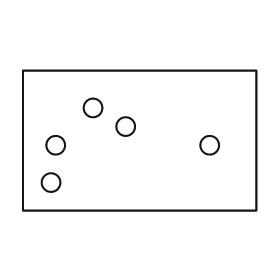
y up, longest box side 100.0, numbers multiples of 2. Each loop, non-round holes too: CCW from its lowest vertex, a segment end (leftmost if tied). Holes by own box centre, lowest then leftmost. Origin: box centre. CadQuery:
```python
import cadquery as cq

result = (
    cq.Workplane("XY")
    .moveTo(-50.0, -30.0)
    .lineTo(50.0, -30.0)
    .lineTo(50.0, 30.0)
    .lineTo(-50.0, 30.0)
    .close()
    .moveTo(-38.0, -18.0)
    .circle(4.0)
    .moveTo(-36.0, -2.0)
    .circle(4.0)
    .moveTo(30.0, -2.0)
    .circle(4.0)
    .moveTo(-6.0, 6.0)
    .circle(4.0)
    .moveTo(-20.0, 14.0)
    .circle(4.0)
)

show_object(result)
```